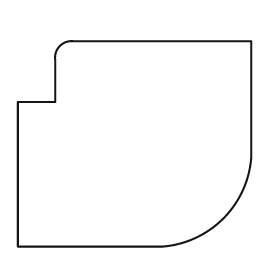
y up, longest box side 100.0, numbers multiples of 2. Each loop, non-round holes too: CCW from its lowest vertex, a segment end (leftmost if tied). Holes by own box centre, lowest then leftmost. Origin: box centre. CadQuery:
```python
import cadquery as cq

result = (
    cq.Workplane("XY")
    .moveTo(-50.0, -44.0)
    .lineTo(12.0, -44.0)
    .threePointArc((38.0, -32.0), (50.0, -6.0))
    .lineTo(50.0, 44.0)
    .lineTo(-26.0, 44.0)
    .threePointArc((-32.0, 42.0), (-34.0, 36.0))
    .lineTo(-34.0, 18.0)
    .lineTo(-50.0, 18.0)
    .close()
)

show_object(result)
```